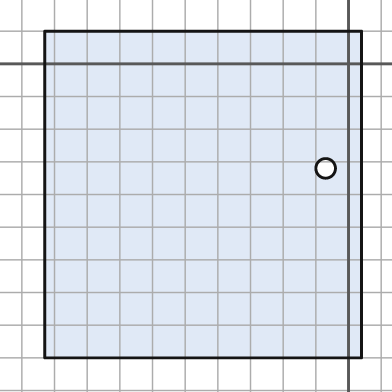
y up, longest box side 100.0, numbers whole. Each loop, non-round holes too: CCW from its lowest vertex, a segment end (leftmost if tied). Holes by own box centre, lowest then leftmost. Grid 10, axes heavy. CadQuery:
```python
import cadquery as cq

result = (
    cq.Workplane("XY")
    .moveTo(-93.0, -90.0)
    .lineTo(4.0, -90.0)
    .lineTo(4.0, 10.0)
    .lineTo(-93.0, 10.0)
    .close()
    .moveTo(-7.0, -32.0)
    .circle(3.0)
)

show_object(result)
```